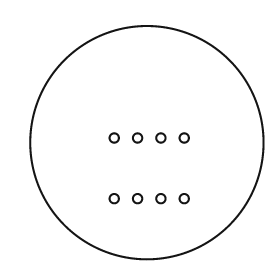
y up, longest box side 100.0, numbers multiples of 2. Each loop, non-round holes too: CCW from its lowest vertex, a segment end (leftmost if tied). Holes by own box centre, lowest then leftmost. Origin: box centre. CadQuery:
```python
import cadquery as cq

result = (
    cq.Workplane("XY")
    .moveTo(0.0, 0.0)
    .circle(50.0)
    .moveTo(-14.0, -24.0)
    .circle(2.0)
    .moveTo(-4.0, -24.0)
    .circle(2.0)
    .moveTo(6.0, -24.0)
    .circle(2.0)
    .moveTo(16.0, -24.0)
    .circle(2.0)
    .moveTo(-14.0, 2.0)
    .circle(2.0)
    .moveTo(-4.0, 2.0)
    .circle(2.0)
    .moveTo(6.0, 2.0)
    .circle(2.0)
    .moveTo(16.0, 2.0)
    .circle(2.0)
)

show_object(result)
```